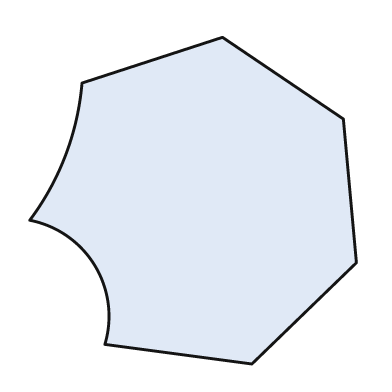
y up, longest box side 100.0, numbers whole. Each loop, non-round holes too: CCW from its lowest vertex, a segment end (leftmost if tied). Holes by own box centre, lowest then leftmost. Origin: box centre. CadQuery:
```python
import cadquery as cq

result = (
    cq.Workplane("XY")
    .moveTo(18.0, -50.0)
    .lineTo(50.0, -19.0)
    .lineTo(46.0, 25.0)
    .lineTo(9.0, 50.0)
    .lineTo(-34.0, 36.0)
    .threePointArc((-39.0, 14.0), (-50.0, -6.0))
    .threePointArc((-30.0, -20.0), (-27.0, -44.0))
    .close()
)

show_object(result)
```